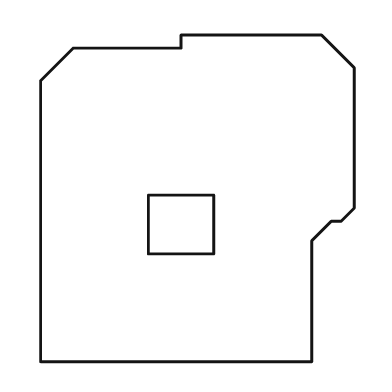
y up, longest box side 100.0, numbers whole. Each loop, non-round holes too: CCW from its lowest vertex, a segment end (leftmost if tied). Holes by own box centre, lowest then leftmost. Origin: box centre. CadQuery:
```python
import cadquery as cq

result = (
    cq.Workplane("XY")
    .moveTo(-48.0, -50.0)
    .lineTo(35.0, -50.0)
    .lineTo(35.0, -13.0)
    .lineTo(41.0, -7.0)
    .lineTo(44.0, -7.0)
    .lineTo(48.0, -3.0)
    .lineTo(48.0, 40.0)
    .lineTo(38.0, 50.0)
    .lineTo(-5.0, 50.0)
    .lineTo(-5.0, 46.0)
    .lineTo(-38.0, 46.0)
    .lineTo(-48.0, 36.0)
    .close()
    .moveTo(-15.0, -17.0)
    .lineTo(5.0, -17.0)
    .lineTo(5.0, 1.0)
    .lineTo(-15.0, 1.0)
    .close()
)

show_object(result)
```